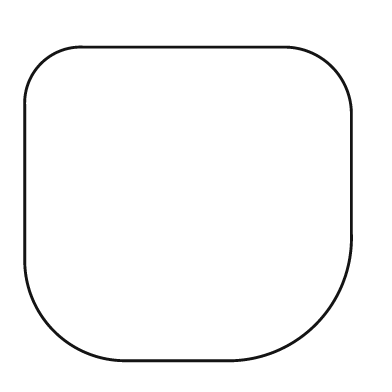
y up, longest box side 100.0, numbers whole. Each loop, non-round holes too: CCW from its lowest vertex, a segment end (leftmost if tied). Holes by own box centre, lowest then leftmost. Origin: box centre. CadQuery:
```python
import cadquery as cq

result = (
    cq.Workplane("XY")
    .moveTo(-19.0, -48.0)
    .lineTo(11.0, -48.0)
    .threePointArc((39.0, -37.0), (50.0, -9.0))
    .lineTo(50.0, 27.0)
    .threePointArc((44.0, 42.0), (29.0, 48.0))
    .lineTo(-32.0, 48.0)
    .threePointArc((-45.0, 43.0), (-50.0, 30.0))
    .lineTo(-50.0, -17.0)
    .threePointArc((-41.0, -39.0), (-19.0, -48.0))
    .close()
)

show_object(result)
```